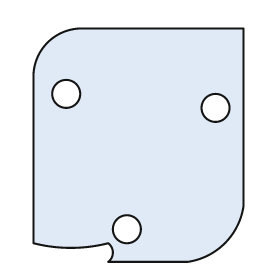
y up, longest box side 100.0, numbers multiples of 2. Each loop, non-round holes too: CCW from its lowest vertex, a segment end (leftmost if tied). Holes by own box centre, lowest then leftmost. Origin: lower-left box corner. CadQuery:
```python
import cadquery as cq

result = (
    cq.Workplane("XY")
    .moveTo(32.0, 0.0)
    .lineTo(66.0, 0.0)
    .threePointArc((82.0, 8.0), (90.0, 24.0))
    .lineTo(90.0, 100.0)
    .lineTo(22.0, 100.0)
    .threePointArc((6.0, 94.0), (0.0, 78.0))
    .lineTo(0.0, 8.0)
    .threePointArc((16.0, 6.0), (32.0, 8.0))
    .threePointArc((34.0, 4.0), (32.0, 0.0))
    .close()
    .moveTo(40.0, 14.0)
    .circle(6.0)
    .moveTo(78.0, 66.0)
    .circle(6.0)
    .moveTo(14.0, 72.0)
    .circle(6.0)
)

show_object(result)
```